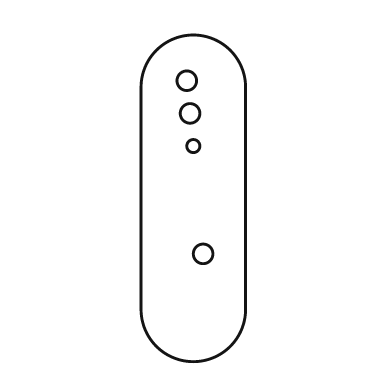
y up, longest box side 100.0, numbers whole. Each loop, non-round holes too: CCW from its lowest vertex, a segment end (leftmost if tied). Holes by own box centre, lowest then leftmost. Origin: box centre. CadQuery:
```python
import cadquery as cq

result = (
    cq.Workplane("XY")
    .moveTo(-16.0, -34.0)
    .threePointArc((0.0, -50.0), (16.0, -34.0))
    .lineTo(16.0, 34.0)
    .threePointArc((0.0, 50.0), (-16.0, 34.0))
    .close()
    .moveTo(3.0, -17.0)
    .circle(3.0)
    .moveTo(0.0, 16.0)
    .circle(2.0)
    .moveTo(-1.0, 26.0)
    .circle(3.0)
    .moveTo(-2.0, 36.0)
    .circle(3.0)
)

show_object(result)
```